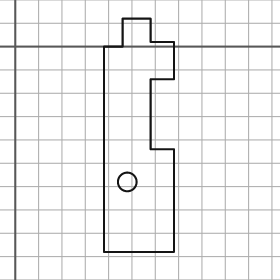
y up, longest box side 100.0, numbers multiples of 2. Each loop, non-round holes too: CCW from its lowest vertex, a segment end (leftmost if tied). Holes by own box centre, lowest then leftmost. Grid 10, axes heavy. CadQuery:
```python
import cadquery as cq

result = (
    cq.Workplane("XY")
    .moveTo(38.0, -88.0)
    .lineTo(68.0, -88.0)
    .lineTo(68.0, -44.0)
    .lineTo(58.0, -44.0)
    .lineTo(58.0, -14.0)
    .lineTo(68.0, -14.0)
    .lineTo(68.0, 2.0)
    .lineTo(58.0, 2.0)
    .lineTo(58.0, 12.0)
    .lineTo(46.0, 12.0)
    .lineTo(46.0, 0.0)
    .lineTo(38.0, 0.0)
    .close()
    .moveTo(48.0, -58.0)
    .circle(4.0)
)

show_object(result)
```